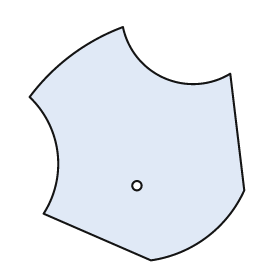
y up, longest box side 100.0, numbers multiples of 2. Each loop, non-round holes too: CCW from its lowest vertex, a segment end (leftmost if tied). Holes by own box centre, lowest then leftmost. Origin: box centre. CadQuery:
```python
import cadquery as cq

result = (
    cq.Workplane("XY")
    .moveTo(6.0, -50.0)
    .threePointArc((30.0, -40.0), (46.0, -20.0))
    .lineTo(40.0, 30.0)
    .threePointArc((12.0, 28.0), (-6.0, 50.0))
    .threePointArc((-28.0, 38.0), (-46.0, 20.0))
    .threePointArc((-34.0, -4.0), (-40.0, -30.0))
    .close()
    .moveTo(0.0, -18.0)
    .circle(2.0)
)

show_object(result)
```